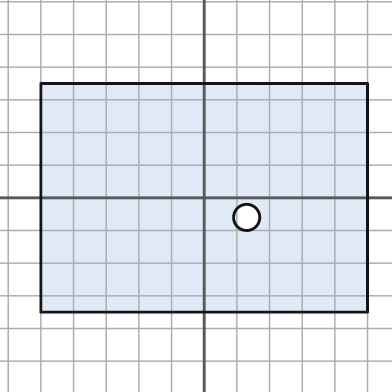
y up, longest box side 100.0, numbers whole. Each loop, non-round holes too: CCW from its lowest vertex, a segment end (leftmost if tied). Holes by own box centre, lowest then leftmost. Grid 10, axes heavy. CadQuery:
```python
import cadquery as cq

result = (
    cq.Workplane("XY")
    .moveTo(-50.0, -35.0)
    .lineTo(50.0, -35.0)
    .lineTo(50.0, 35.0)
    .lineTo(-50.0, 35.0)
    .close()
    .moveTo(13.0, -6.0)
    .circle(4.0)
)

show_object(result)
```